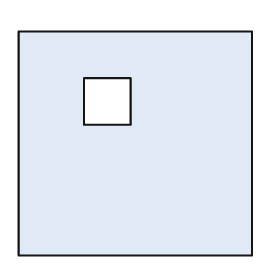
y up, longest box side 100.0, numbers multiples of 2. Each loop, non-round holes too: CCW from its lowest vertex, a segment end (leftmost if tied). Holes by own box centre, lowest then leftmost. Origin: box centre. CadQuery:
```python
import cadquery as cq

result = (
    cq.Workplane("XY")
    .moveTo(-50.0, -48.0)
    .lineTo(50.0, -48.0)
    .lineTo(50.0, 48.0)
    .lineTo(-50.0, 48.0)
    .close()
    .moveTo(-22.0, 8.0)
    .lineTo(-2.0, 8.0)
    .lineTo(-2.0, 28.0)
    .lineTo(-22.0, 28.0)
    .close()
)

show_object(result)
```